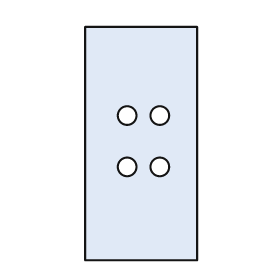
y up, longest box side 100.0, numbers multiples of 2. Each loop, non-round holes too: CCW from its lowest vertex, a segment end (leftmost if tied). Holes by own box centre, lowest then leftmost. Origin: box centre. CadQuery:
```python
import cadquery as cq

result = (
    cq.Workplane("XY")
    .moveTo(-24.0, -50.0)
    .lineTo(24.0, -50.0)
    .lineTo(24.0, 50.0)
    .lineTo(-24.0, 50.0)
    .close()
    .moveTo(-6.0, -10.0)
    .circle(4.0)
    .moveTo(8.0, -10.0)
    .circle(4.0)
    .moveTo(-6.0, 12.0)
    .circle(4.0)
    .moveTo(8.0, 12.0)
    .circle(4.0)
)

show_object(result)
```